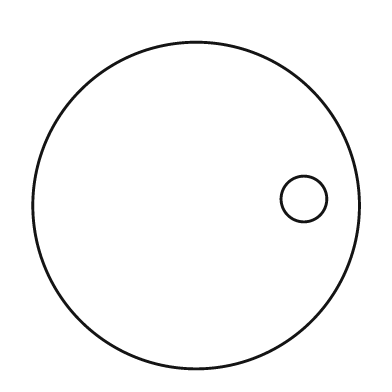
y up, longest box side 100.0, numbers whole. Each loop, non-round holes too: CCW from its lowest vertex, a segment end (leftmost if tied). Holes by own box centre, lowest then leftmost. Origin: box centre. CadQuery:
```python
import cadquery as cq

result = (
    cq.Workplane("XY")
    .moveTo(0.0, 0.0)
    .circle(50.0)
    .moveTo(33.0, 2.0)
    .circle(7.0)
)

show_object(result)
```